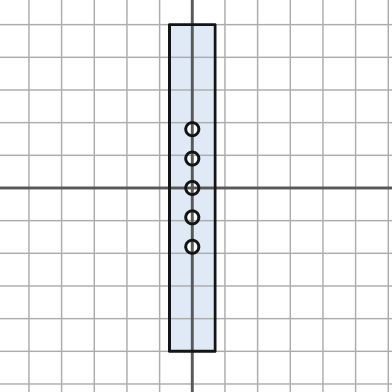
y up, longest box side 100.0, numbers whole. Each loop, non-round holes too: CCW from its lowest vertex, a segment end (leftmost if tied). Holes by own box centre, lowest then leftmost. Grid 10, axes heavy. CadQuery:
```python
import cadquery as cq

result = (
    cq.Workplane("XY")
    .moveTo(-7.0, -50.0)
    .lineTo(7.0, -50.0)
    .lineTo(7.0, 50.0)
    .lineTo(-7.0, 50.0)
    .close()
    .moveTo(0.0, -18.0)
    .circle(2.0)
    .moveTo(0.0, -9.0)
    .circle(2.0)
    .moveTo(0.0, 0.0)
    .circle(2.0)
    .moveTo(0.0, 9.0)
    .circle(2.0)
    .moveTo(0.0, 18.0)
    .circle(2.0)
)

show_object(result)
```